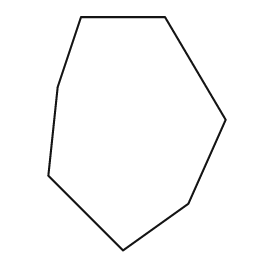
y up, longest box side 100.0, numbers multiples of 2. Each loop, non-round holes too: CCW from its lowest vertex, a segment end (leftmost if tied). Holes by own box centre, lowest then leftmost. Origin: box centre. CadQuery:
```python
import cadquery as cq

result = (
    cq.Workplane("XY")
    .moveTo(-6.0, -50.0)
    .lineTo(22.0, -30.0)
    .lineTo(38.0, 6.0)
    .lineTo(12.0, 50.0)
    .lineTo(-24.0, 50.0)
    .lineTo(-34.0, 20.0)
    .lineTo(-38.0, -18.0)
    .close()
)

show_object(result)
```